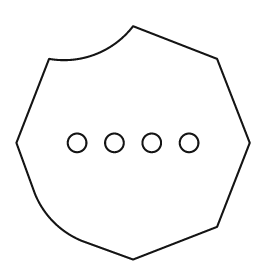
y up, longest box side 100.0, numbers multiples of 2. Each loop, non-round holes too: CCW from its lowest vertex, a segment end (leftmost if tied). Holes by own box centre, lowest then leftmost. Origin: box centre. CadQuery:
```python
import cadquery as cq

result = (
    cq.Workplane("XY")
    .moveTo(0.0, -50.0)
    .lineTo(36.0, -36.0)
    .lineTo(50.0, 0.0)
    .lineTo(36.0, 36.0)
    .lineTo(0.0, 50.0)
    .threePointArc((-16.0, 38.0), (-36.0, 36.0))
    .lineTo(-50.0, 0.0)
    .lineTo(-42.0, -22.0)
    .threePointArc((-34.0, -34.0), (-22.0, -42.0))
    .close()
    .moveTo(-24.0, 0.0)
    .circle(4.0)
    .moveTo(-8.0, 0.0)
    .circle(4.0)
    .moveTo(8.0, 0.0)
    .circle(4.0)
    .moveTo(24.0, 0.0)
    .circle(4.0)
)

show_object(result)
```